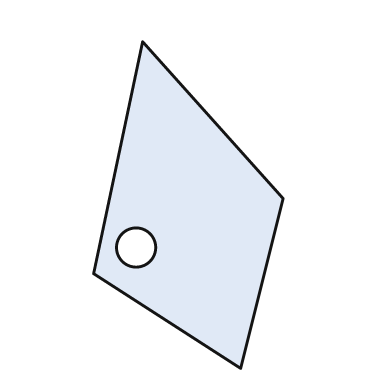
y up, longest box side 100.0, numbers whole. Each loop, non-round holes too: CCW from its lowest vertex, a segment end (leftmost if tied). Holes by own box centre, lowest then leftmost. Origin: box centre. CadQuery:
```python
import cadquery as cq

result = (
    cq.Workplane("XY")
    .moveTo(16.0, -50.0)
    .lineTo(29.0, 2.0)
    .lineTo(-14.0, 50.0)
    .lineTo(-29.0, -21.0)
    .close()
    .moveTo(-16.0, -13.0)
    .circle(6.0)
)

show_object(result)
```